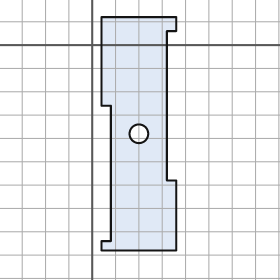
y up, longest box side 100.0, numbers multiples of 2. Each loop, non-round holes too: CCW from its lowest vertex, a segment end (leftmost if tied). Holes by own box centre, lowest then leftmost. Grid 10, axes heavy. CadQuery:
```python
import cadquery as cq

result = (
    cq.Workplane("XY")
    .moveTo(4.0, -88.0)
    .lineTo(36.0, -88.0)
    .lineTo(36.0, -58.0)
    .lineTo(32.0, -58.0)
    .lineTo(32.0, 6.0)
    .lineTo(36.0, 6.0)
    .lineTo(36.0, 12.0)
    .lineTo(4.0, 12.0)
    .lineTo(4.0, -26.0)
    .lineTo(8.0, -26.0)
    .lineTo(8.0, -84.0)
    .lineTo(4.0, -84.0)
    .close()
    .moveTo(20.0, -38.0)
    .circle(4.0)
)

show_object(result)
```